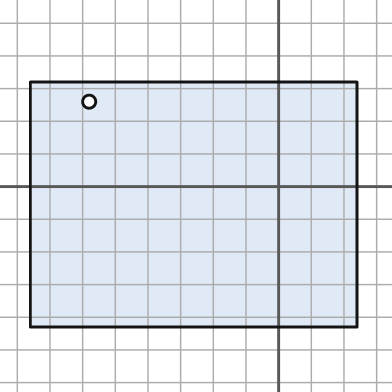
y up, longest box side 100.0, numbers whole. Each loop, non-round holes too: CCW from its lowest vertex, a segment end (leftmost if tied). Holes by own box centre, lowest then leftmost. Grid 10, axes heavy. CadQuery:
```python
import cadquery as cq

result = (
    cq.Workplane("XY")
    .moveTo(-76.0, -43.0)
    .lineTo(24.0, -43.0)
    .lineTo(24.0, 32.0)
    .lineTo(-76.0, 32.0)
    .close()
    .moveTo(-58.0, 26.0)
    .circle(2.0)
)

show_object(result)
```